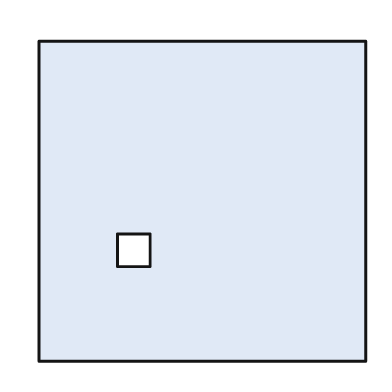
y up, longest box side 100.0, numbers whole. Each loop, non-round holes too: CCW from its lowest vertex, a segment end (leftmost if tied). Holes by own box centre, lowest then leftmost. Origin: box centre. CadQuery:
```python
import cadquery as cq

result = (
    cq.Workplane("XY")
    .moveTo(-50.0, -49.0)
    .lineTo(50.0, -49.0)
    .lineTo(50.0, 49.0)
    .lineTo(-50.0, 49.0)
    .close()
    .moveTo(-26.0, -20.0)
    .lineTo(-16.0, -20.0)
    .lineTo(-16.0, -10.0)
    .lineTo(-26.0, -10.0)
    .close()
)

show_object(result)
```